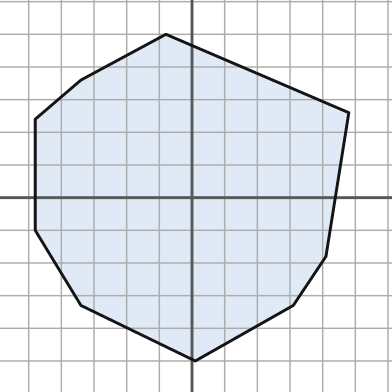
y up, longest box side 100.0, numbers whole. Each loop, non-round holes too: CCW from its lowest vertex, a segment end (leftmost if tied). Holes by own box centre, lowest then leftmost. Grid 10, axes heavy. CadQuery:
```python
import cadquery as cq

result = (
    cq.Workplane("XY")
    .moveTo(1.0, -50.0)
    .lineTo(31.0, -33.0)
    .lineTo(41.0, -18.0)
    .lineTo(48.0, 26.0)
    .lineTo(-8.0, 50.0)
    .lineTo(-34.0, 36.0)
    .lineTo(-48.0, 24.0)
    .lineTo(-48.0, -10.0)
    .lineTo(-34.0, -33.0)
    .close()
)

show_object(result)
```